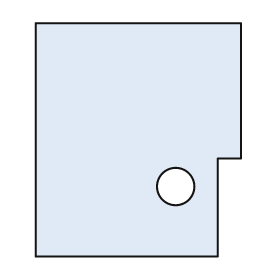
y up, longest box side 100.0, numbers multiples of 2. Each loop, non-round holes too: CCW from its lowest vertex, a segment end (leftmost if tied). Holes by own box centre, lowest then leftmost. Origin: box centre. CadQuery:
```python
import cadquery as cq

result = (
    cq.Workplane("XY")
    .moveTo(-44.0, -50.0)
    .lineTo(34.0, -50.0)
    .lineTo(34.0, -8.0)
    .lineTo(44.0, -8.0)
    .lineTo(44.0, 50.0)
    .lineTo(-44.0, 50.0)
    .close()
    .moveTo(16.0, -20.0)
    .circle(8.0)
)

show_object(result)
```